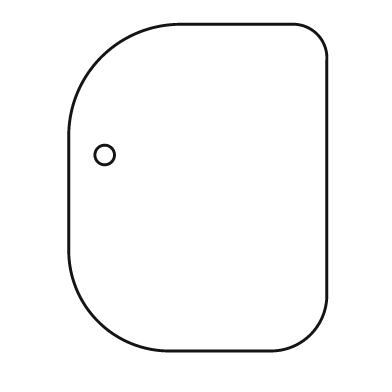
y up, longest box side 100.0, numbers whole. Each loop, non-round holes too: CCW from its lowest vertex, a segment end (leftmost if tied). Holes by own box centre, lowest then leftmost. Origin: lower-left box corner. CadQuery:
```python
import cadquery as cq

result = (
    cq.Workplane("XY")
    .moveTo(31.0, 0.0)
    .lineTo(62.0, 0.0)
    .threePointArc((74.0, 5.0), (79.0, 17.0))
    .lineTo(79.0, 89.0)
    .threePointArc((76.0, 97.0), (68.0, 100.0))
    .lineTo(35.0, 100.0)
    .threePointArc((10.0, 90.0), (0.0, 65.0))
    .lineTo(0.0, 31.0)
    .threePointArc((9.0, 9.0), (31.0, 0.0))
    .close()
    .moveTo(11.0, 60.0)
    .circle(3.0)
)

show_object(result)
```